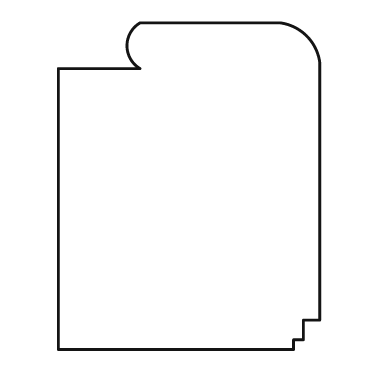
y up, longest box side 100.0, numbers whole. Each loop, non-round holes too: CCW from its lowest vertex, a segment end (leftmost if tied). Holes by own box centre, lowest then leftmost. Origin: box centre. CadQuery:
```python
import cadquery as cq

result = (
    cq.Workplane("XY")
    .moveTo(-40.0, -50.0)
    .lineTo(32.0, -50.0)
    .lineTo(32.0, -47.0)
    .lineTo(35.0, -47.0)
    .lineTo(35.0, -41.0)
    .lineTo(40.0, -41.0)
    .lineTo(40.0, 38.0)
    .threePointArc((36.0, 46.0), (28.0, 50.0))
    .lineTo(-15.0, 50.0)
    .threePointArc((-19.0, 43.0), (-15.0, 36.0))
    .lineTo(-40.0, 36.0)
    .close()
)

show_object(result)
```